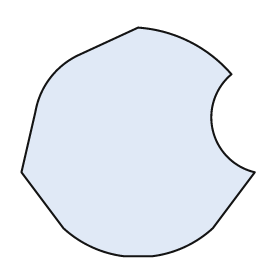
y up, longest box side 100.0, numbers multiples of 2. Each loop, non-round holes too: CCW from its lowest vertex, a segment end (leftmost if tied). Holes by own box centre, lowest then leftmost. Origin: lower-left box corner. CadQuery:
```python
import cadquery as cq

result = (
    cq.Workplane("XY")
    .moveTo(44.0, 0.0)
    .lineTo(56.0, 0.0)
    .threePointArc((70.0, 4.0), (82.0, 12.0))
    .lineTo(100.0, 36.0)
    .threePointArc((82.0, 54.0), (90.0, 78.0))
    .threePointArc((72.0, 92.0), (50.0, 98.0))
    .lineTo(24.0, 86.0)
    .threePointArc((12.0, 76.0), (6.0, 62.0))
    .lineTo(0.0, 36.0)
    .lineTo(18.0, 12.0)
    .threePointArc((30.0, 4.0), (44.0, 0.0))
    .close()
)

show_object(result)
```